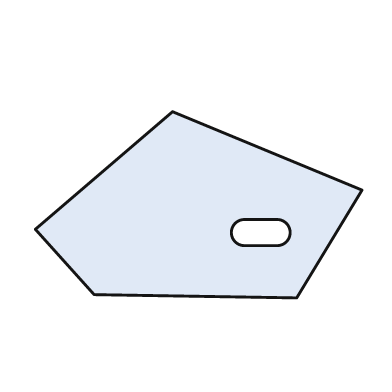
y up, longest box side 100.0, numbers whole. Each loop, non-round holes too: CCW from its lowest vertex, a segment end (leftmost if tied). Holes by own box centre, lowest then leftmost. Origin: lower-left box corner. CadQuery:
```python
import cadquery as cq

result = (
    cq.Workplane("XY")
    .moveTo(80.0, 0.0)
    .lineTo(100.0, 33.0)
    .lineTo(42.0, 57.0)
    .lineTo(0.0, 21.0)
    .lineTo(18.0, 1.0)
    .close()
    .moveTo(64.0, 16.0)
    .lineTo(74.0, 16.0)
    .threePointArc((78.0, 20.0), (74.0, 24.0))
    .lineTo(64.0, 24.0)
    .threePointArc((60.0, 20.0), (64.0, 16.0))
    .close()
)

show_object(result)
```